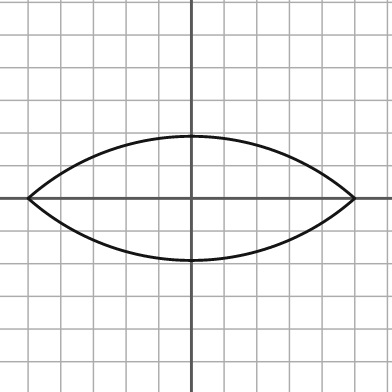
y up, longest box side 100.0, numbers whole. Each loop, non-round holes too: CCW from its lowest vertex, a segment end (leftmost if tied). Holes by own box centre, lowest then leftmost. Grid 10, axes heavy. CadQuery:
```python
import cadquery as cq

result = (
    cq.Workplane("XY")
    .moveTo(-50.0, 0.0)
    .threePointArc((0.0, -19.0), (50.0, 0.0))
    .threePointArc((0.0, 19.0), (-50.0, 0.0))
    .close()
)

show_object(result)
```